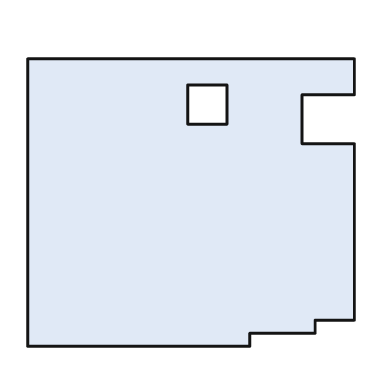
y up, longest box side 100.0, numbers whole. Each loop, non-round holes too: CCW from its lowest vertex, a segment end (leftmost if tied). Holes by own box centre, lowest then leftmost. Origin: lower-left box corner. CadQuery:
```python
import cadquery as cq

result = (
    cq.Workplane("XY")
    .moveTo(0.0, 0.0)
    .lineTo(68.0, 0.0)
    .lineTo(68.0, 4.0)
    .lineTo(88.0, 4.0)
    .lineTo(88.0, 8.0)
    .lineTo(100.0, 8.0)
    .lineTo(100.0, 62.0)
    .lineTo(84.0, 62.0)
    .lineTo(84.0, 77.0)
    .lineTo(100.0, 77.0)
    .lineTo(100.0, 88.0)
    .lineTo(0.0, 88.0)
    .close()
    .moveTo(49.0, 68.0)
    .lineTo(61.0, 68.0)
    .lineTo(61.0, 80.0)
    .lineTo(49.0, 80.0)
    .close()
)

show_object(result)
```